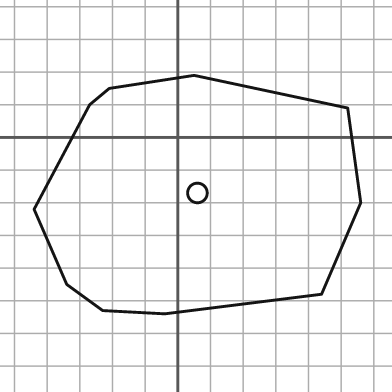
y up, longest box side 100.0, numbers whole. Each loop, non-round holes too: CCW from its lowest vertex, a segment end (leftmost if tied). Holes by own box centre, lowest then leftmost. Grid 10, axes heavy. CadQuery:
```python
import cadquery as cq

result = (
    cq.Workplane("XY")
    .moveTo(-4.0, -54.0)
    .lineTo(44.0, -48.0)
    .lineTo(56.0, -20.0)
    .lineTo(52.0, 9.0)
    .lineTo(5.0, 19.0)
    .lineTo(-21.0, 15.0)
    .lineTo(-27.0, 10.0)
    .lineTo(-44.0, -22.0)
    .lineTo(-34.0, -45.0)
    .lineTo(-23.0, -53.0)
    .close()
    .moveTo(6.0, -17.0)
    .circle(3.0)
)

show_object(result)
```